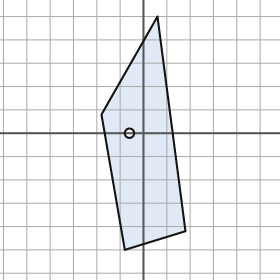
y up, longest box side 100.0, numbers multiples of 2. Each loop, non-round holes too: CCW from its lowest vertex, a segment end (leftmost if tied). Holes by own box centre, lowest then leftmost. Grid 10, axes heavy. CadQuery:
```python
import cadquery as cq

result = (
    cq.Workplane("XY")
    .moveTo(-8.0, -50.0)
    .lineTo(18.0, -42.0)
    .lineTo(6.0, 50.0)
    .lineTo(-18.0, 8.0)
    .close()
    .moveTo(-6.0, 0.0)
    .circle(2.0)
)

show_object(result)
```